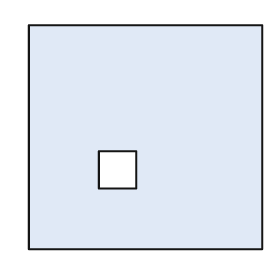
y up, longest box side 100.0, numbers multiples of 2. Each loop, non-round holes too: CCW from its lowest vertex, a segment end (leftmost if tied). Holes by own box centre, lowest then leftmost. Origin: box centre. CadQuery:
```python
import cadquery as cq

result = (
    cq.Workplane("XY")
    .moveTo(-50.0, -48.0)
    .lineTo(50.0, -48.0)
    .lineTo(50.0, 48.0)
    .lineTo(-50.0, 48.0)
    .close()
    .moveTo(-20.0, -22.0)
    .lineTo(-4.0, -22.0)
    .lineTo(-4.0, -6.0)
    .lineTo(-20.0, -6.0)
    .close()
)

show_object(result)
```